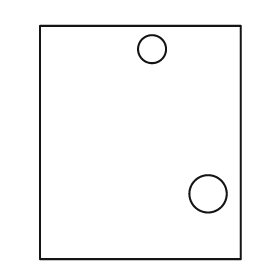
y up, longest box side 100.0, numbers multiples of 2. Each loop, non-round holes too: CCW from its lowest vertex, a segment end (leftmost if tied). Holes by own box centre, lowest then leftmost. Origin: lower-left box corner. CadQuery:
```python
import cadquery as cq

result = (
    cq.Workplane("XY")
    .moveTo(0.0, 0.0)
    .lineTo(86.0, 0.0)
    .lineTo(86.0, 100.0)
    .lineTo(0.0, 100.0)
    .close()
    .moveTo(72.0, 28.0)
    .circle(8.0)
    .moveTo(48.0, 90.0)
    .circle(6.0)
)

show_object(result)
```